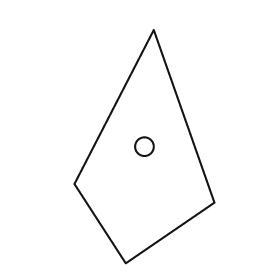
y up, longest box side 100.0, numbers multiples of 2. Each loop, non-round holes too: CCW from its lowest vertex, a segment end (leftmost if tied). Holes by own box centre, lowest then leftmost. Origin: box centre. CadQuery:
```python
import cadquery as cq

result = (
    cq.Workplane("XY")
    .moveTo(-8.0, -50.0)
    .lineTo(30.0, -24.0)
    .lineTo(4.0, 50.0)
    .lineTo(-30.0, -16.0)
    .close()
    .moveTo(0.0, 0.0)
    .circle(4.0)
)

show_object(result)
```